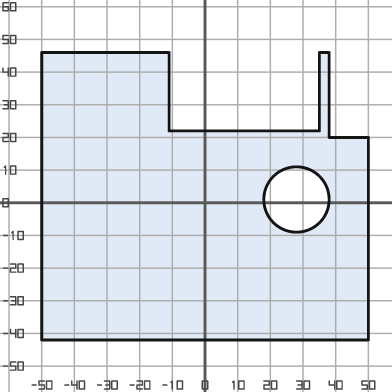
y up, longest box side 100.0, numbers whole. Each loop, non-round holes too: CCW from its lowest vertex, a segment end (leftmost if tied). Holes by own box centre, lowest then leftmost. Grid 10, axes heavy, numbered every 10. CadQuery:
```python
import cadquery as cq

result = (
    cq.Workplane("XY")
    .moveTo(-50.0, -42.0)
    .lineTo(50.0, -42.0)
    .lineTo(50.0, 20.0)
    .lineTo(38.0, 20.0)
    .lineTo(38.0, 46.0)
    .lineTo(35.0, 46.0)
    .lineTo(35.0, 22.0)
    .lineTo(-11.0, 22.0)
    .lineTo(-11.0, 46.0)
    .lineTo(-50.0, 46.0)
    .close()
    .moveTo(28.0, 1.0)
    .circle(10.0)
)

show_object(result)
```